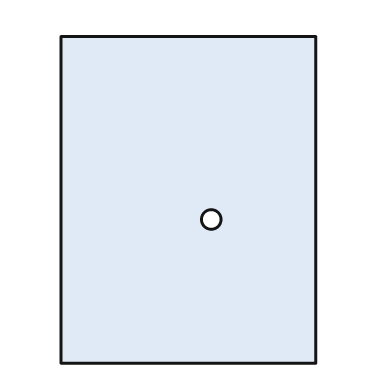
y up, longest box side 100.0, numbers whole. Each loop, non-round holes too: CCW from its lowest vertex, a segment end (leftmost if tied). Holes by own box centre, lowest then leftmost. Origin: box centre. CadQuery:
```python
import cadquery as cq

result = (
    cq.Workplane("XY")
    .moveTo(-39.0, -50.0)
    .lineTo(39.0, -50.0)
    .lineTo(39.0, 50.0)
    .lineTo(-39.0, 50.0)
    .close()
    .moveTo(7.0, -6.0)
    .circle(3.0)
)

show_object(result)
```